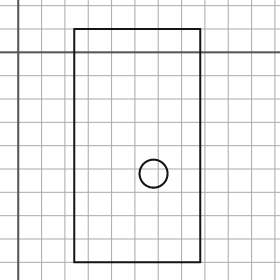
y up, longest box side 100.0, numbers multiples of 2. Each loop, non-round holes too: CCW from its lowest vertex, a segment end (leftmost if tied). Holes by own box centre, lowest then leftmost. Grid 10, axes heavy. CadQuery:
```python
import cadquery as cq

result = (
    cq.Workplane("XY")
    .moveTo(24.0, -90.0)
    .lineTo(78.0, -90.0)
    .lineTo(78.0, 10.0)
    .lineTo(24.0, 10.0)
    .close()
    .moveTo(58.0, -52.0)
    .circle(6.0)
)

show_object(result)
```